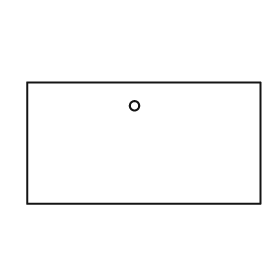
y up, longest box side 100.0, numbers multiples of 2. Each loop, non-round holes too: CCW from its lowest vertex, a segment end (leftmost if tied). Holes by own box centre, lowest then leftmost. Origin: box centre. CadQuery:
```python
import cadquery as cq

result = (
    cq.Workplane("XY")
    .moveTo(-50.0, -26.0)
    .lineTo(50.0, -26.0)
    .lineTo(50.0, 26.0)
    .lineTo(-50.0, 26.0)
    .close()
    .moveTo(-4.0, 16.0)
    .circle(2.0)
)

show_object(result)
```